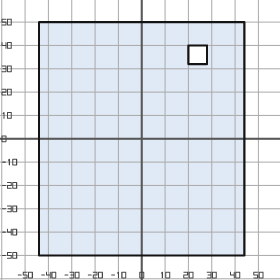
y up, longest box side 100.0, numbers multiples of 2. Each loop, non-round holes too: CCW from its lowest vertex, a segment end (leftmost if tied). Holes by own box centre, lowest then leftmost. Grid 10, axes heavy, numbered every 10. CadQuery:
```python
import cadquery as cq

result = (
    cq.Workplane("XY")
    .moveTo(-44.0, -50.0)
    .lineTo(44.0, -50.0)
    .lineTo(44.0, 50.0)
    .lineTo(-44.0, 50.0)
    .close()
    .moveTo(20.0, 32.0)
    .lineTo(28.0, 32.0)
    .lineTo(28.0, 40.0)
    .lineTo(20.0, 40.0)
    .close()
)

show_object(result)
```